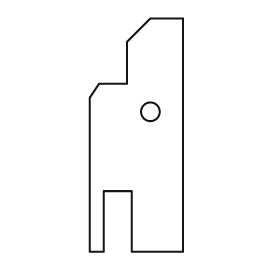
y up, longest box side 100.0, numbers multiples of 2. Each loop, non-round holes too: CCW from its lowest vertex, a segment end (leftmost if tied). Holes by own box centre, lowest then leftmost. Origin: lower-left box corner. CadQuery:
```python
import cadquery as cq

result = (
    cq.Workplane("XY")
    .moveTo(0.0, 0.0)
    .lineTo(6.0, 0.0)
    .lineTo(6.0, 26.0)
    .lineTo(18.0, 26.0)
    .lineTo(18.0, 0.0)
    .lineTo(40.0, 0.0)
    .lineTo(40.0, 100.0)
    .lineTo(26.0, 100.0)
    .lineTo(16.0, 90.0)
    .lineTo(16.0, 72.0)
    .lineTo(4.0, 72.0)
    .lineTo(0.0, 66.0)
    .close()
    .moveTo(26.0, 60.0)
    .circle(4.0)
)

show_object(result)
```